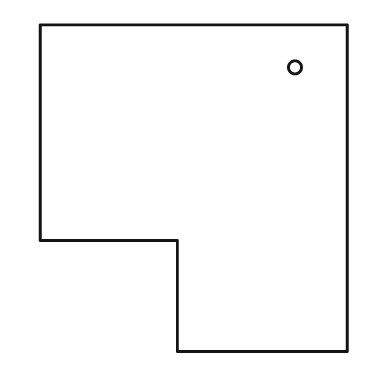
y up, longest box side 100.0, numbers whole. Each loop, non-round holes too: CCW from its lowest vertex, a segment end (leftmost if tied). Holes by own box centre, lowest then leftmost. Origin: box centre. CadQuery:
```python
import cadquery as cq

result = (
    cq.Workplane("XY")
    .moveTo(-5.0, -50.0)
    .lineTo(47.0, -50.0)
    .lineTo(47.0, 50.0)
    .lineTo(-47.0, 50.0)
    .lineTo(-47.0, -16.0)
    .lineTo(-5.0, -16.0)
    .close()
    .moveTo(31.0, 37.0)
    .circle(2.0)
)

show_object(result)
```